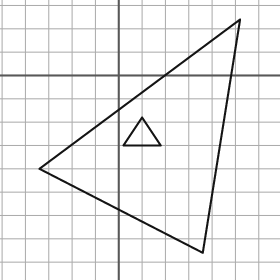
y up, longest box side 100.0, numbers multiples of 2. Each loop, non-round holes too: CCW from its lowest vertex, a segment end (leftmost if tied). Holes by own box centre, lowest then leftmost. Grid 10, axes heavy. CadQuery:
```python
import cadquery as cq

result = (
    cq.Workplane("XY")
    .moveTo(36.0, -76.0)
    .lineTo(52.0, 24.0)
    .lineTo(-34.0, -40.0)
    .close()
    .moveTo(2.0, -30.0)
    .lineTo(18.0, -30.0)
    .lineTo(10.0, -18.0)
    .close()
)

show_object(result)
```